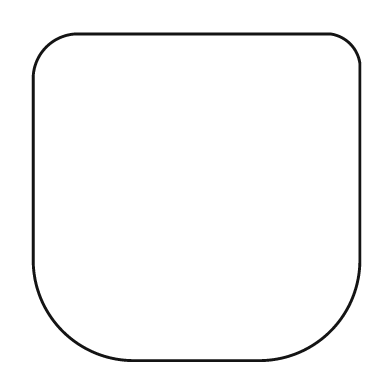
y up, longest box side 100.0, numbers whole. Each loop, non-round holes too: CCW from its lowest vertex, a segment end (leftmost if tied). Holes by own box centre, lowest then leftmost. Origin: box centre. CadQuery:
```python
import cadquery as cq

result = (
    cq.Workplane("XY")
    .moveTo(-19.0, -50.0)
    .lineTo(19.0, -50.0)
    .threePointArc((41.0, -41.0), (50.0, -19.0))
    .lineTo(50.0, 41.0)
    .threePointArc((47.0, 47.0), (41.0, 50.0))
    .lineTo(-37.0, 50.0)
    .threePointArc((-46.0, 46.0), (-50.0, 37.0))
    .lineTo(-50.0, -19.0)
    .threePointArc((-41.0, -41.0), (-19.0, -50.0))
    .close()
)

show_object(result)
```